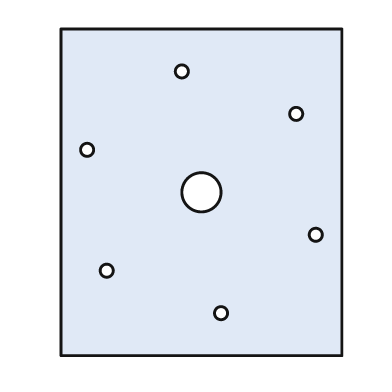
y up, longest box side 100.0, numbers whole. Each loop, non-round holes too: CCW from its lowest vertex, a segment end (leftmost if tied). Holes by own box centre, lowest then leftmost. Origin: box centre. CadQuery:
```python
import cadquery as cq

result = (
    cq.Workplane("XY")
    .moveTo(-43.0, -50.0)
    .lineTo(43.0, -50.0)
    .lineTo(43.0, 50.0)
    .lineTo(-43.0, 50.0)
    .close()
    .moveTo(6.0, -37.0)
    .circle(2.0)
    .moveTo(-29.0, -24.0)
    .circle(2.0)
    .moveTo(35.0, -13.0)
    .circle(2.0)
    .moveTo(0.0, 0.0)
    .circle(6.0)
    .moveTo(-35.0, 13.0)
    .circle(2.0)
    .moveTo(29.0, 24.0)
    .circle(2.0)
    .moveTo(-6.0, 37.0)
    .circle(2.0)
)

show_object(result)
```